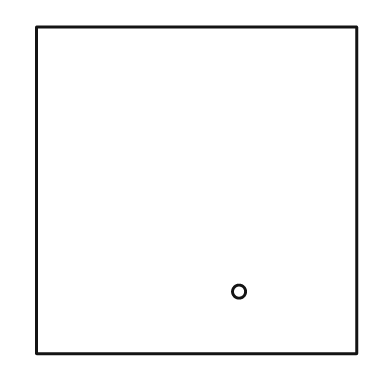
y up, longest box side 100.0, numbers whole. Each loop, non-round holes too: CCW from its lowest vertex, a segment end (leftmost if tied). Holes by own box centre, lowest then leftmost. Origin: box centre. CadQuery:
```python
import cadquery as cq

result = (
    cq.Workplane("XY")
    .moveTo(-49.0, -50.0)
    .lineTo(49.0, -50.0)
    .lineTo(49.0, 50.0)
    .lineTo(-49.0, 50.0)
    .close()
    .moveTo(13.0, -31.0)
    .circle(2.0)
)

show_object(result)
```